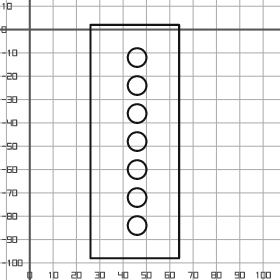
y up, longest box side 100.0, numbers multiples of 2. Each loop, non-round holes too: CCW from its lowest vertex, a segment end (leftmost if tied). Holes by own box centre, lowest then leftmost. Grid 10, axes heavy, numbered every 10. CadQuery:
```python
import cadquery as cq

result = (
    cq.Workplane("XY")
    .moveTo(26.0, -98.0)
    .lineTo(64.0, -98.0)
    .lineTo(64.0, 2.0)
    .lineTo(26.0, 2.0)
    .close()
    .moveTo(46.0, -84.0)
    .circle(4.0)
    .moveTo(46.0, -72.0)
    .circle(4.0)
    .moveTo(46.0, -60.0)
    .circle(4.0)
    .moveTo(46.0, -48.0)
    .circle(4.0)
    .moveTo(46.0, -36.0)
    .circle(4.0)
    .moveTo(46.0, -24.0)
    .circle(4.0)
    .moveTo(46.0, -12.0)
    .circle(4.0)
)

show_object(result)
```